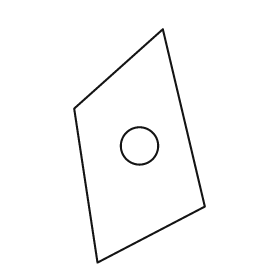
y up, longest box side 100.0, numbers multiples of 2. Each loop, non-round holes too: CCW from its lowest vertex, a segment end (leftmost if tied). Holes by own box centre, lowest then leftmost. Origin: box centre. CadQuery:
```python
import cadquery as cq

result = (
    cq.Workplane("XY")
    .moveTo(-18.0, -50.0)
    .lineTo(28.0, -26.0)
    .lineTo(10.0, 50.0)
    .lineTo(-28.0, 16.0)
    .close()
    .moveTo(0.0, 0.0)
    .circle(8.0)
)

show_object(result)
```